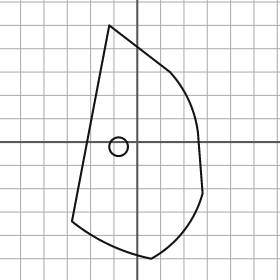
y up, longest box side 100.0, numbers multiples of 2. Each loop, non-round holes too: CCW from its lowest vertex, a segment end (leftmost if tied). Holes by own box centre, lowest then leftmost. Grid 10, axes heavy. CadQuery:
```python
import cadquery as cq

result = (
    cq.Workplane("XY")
    .moveTo(6.0, -50.0)
    .threePointArc((20.0, -38.0), (28.0, -22.0))
    .lineTo(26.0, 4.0)
    .threePointArc((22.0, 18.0), (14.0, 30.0))
    .lineTo(-12.0, 50.0)
    .lineTo(-28.0, -34.0)
    .threePointArc((-12.0, -44.0), (6.0, -50.0))
    .close()
    .moveTo(-8.0, -2.0)
    .circle(4.0)
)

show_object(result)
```